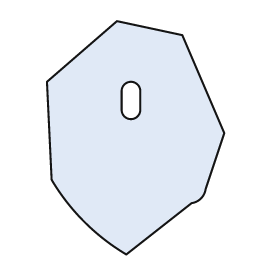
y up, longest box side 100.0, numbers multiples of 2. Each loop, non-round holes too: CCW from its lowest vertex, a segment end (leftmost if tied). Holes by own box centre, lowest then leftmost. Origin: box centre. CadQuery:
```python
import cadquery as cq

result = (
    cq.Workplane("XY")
    .moveTo(-4.0, -50.0)
    .lineTo(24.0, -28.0)
    .threePointArc((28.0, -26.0), (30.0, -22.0))
    .lineTo(38.0, 2.0)
    .lineTo(20.0, 44.0)
    .lineTo(-8.0, 50.0)
    .lineTo(-38.0, 24.0)
    .lineTo(-36.0, -18.0)
    .threePointArc((-22.0, -36.0), (-4.0, -50.0))
    .close()
    .moveTo(-6.0, 12.0)
    .threePointArc((-2.0, 8.0), (2.0, 12.0))
    .lineTo(2.0, 20.0)
    .threePointArc((-2.0, 24.0), (-6.0, 20.0))
    .close()
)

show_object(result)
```